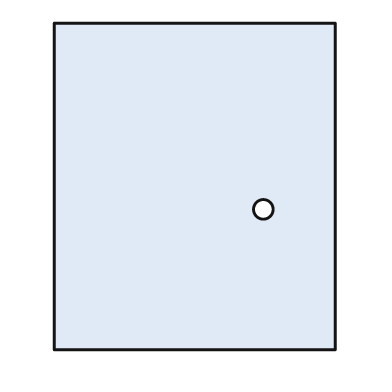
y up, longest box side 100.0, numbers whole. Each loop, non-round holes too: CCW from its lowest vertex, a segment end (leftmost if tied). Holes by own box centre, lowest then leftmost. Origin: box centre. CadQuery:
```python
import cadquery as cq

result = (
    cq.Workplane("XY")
    .moveTo(-43.0, -50.0)
    .lineTo(43.0, -50.0)
    .lineTo(43.0, 50.0)
    .lineTo(-43.0, 50.0)
    .close()
    .moveTo(21.0, -7.0)
    .circle(3.0)
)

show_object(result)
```